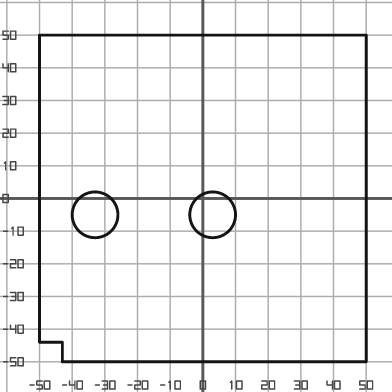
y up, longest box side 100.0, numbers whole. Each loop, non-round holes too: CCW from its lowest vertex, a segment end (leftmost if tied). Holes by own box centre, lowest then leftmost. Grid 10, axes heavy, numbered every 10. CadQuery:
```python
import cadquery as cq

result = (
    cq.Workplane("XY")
    .moveTo(-43.0, -50.0)
    .lineTo(50.0, -50.0)
    .lineTo(50.0, 50.0)
    .lineTo(-50.0, 50.0)
    .lineTo(-50.0, -44.0)
    .lineTo(-43.0, -44.0)
    .close()
    .moveTo(-33.0, -5.0)
    .circle(7.0)
    .moveTo(3.0, -5.0)
    .circle(7.0)
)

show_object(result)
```